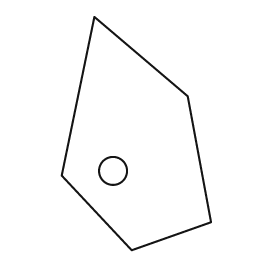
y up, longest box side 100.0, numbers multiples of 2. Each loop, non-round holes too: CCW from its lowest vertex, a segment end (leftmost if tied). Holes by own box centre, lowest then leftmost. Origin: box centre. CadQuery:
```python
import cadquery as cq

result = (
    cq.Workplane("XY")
    .moveTo(-2.0, -50.0)
    .lineTo(32.0, -38.0)
    .lineTo(22.0, 16.0)
    .lineTo(-18.0, 50.0)
    .lineTo(-32.0, -18.0)
    .close()
    .moveTo(-10.0, -16.0)
    .circle(6.0)
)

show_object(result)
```